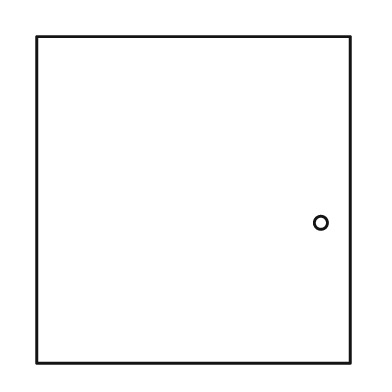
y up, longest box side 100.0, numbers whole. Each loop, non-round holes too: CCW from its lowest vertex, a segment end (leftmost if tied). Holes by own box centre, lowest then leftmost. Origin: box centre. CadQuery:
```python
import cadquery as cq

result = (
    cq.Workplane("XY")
    .moveTo(-48.0, -50.0)
    .lineTo(48.0, -50.0)
    .lineTo(48.0, 50.0)
    .lineTo(-48.0, 50.0)
    .close()
    .moveTo(39.0, -7.0)
    .circle(2.0)
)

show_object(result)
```